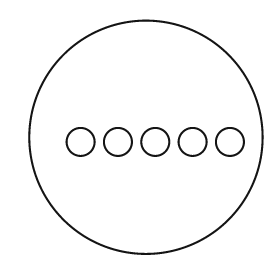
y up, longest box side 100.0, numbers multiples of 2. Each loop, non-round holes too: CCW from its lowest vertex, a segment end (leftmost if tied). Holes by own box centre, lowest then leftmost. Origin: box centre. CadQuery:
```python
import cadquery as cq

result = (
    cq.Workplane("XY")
    .moveTo(0.0, 0.0)
    .circle(50.0)
    .moveTo(-28.0, -2.0)
    .circle(6.0)
    .moveTo(-12.0, -2.0)
    .circle(6.0)
    .moveTo(4.0, -2.0)
    .circle(6.0)
    .moveTo(20.0, -2.0)
    .circle(6.0)
    .moveTo(36.0, -2.0)
    .circle(6.0)
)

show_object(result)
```